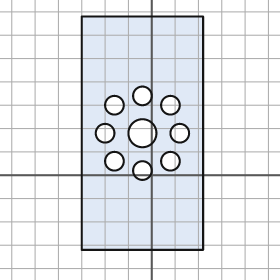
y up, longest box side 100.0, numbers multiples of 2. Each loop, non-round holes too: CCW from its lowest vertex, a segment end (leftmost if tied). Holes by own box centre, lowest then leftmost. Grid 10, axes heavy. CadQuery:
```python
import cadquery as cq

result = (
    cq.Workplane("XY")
    .moveTo(-30.0, -32.0)
    .lineTo(22.0, -32.0)
    .lineTo(22.0, 68.0)
    .lineTo(-30.0, 68.0)
    .close()
    .moveTo(-4.0, 2.0)
    .circle(4.0)
    .moveTo(-16.0, 6.0)
    .circle(4.0)
    .moveTo(8.0, 6.0)
    .circle(4.0)
    .moveTo(-20.0, 18.0)
    .circle(4.0)
    .moveTo(-4.0, 18.0)
    .circle(6.0)
    .moveTo(12.0, 18.0)
    .circle(4.0)
    .moveTo(-16.0, 30.0)
    .circle(4.0)
    .moveTo(8.0, 30.0)
    .circle(4.0)
    .moveTo(-4.0, 34.0)
    .circle(4.0)
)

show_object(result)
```